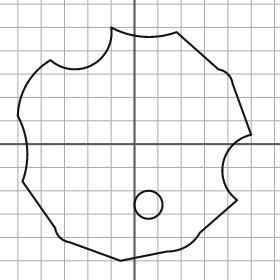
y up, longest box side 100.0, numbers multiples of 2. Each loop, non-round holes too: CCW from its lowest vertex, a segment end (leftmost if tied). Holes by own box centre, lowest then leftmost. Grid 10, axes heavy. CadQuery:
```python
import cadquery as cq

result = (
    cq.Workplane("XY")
    .moveTo(-6.0, -50.0)
    .lineTo(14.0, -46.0)
    .threePointArc((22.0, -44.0), (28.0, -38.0))
    .lineTo(44.0, -24.0)
    .threePointArc((38.0, -8.0), (50.0, 4.0))
    .lineTo(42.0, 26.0)
    .threePointArc((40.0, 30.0), (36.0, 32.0))
    .lineTo(18.0, 48.0)
    .threePointArc((4.0, 46.0), (-10.0, 50.0))
    .threePointArc((-18.0, 34.0), (-36.0, 36.0))
    .threePointArc((-46.0, 26.0), (-50.0, 12.0))
    .threePointArc((-46.0, -2.0), (-48.0, -16.0))
    .lineTo(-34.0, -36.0)
    .threePointArc((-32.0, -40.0), (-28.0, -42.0))
    .close()
    .moveTo(6.0, -26.0)
    .circle(6.0)
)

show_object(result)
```